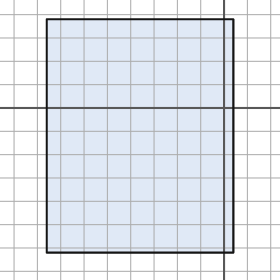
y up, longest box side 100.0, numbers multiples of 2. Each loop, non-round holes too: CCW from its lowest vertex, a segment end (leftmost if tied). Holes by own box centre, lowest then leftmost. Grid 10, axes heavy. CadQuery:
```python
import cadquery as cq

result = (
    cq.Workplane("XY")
    .moveTo(-76.0, -62.0)
    .lineTo(4.0, -62.0)
    .lineTo(4.0, 38.0)
    .lineTo(-76.0, 38.0)
    .close()
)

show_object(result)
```